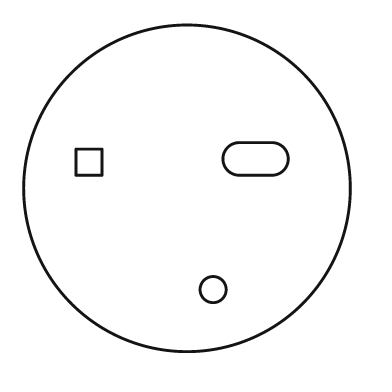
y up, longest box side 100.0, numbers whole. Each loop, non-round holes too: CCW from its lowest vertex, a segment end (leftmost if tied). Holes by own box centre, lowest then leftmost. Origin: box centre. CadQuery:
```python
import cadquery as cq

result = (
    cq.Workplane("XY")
    .moveTo(0.0, 0.0)
    .circle(50.0)
    .moveTo(8.0, -31.0)
    .circle(4.0)
    .moveTo(-34.0, 4.0)
    .lineTo(-26.0, 4.0)
    .lineTo(-26.0, 12.0)
    .lineTo(-34.0, 12.0)
    .close()
    .moveTo(16.0, 4.0)
    .lineTo(26.0, 4.0)
    .threePointArc((31.0, 9.0), (26.0, 14.0))
    .lineTo(16.0, 14.0)
    .threePointArc((11.0, 9.0), (16.0, 4.0))
    .close()
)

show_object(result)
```